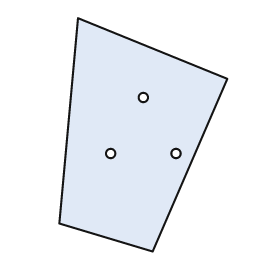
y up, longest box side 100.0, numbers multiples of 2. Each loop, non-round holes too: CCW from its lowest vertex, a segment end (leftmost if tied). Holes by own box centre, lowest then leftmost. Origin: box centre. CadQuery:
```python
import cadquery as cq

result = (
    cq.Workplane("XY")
    .moveTo(4.0, -50.0)
    .lineTo(36.0, 24.0)
    .lineTo(-28.0, 50.0)
    .lineTo(-36.0, -38.0)
    .close()
    .moveTo(-14.0, -8.0)
    .circle(2.0)
    .moveTo(14.0, -8.0)
    .circle(2.0)
    .moveTo(0.0, 16.0)
    .circle(2.0)
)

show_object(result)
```